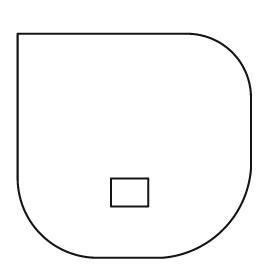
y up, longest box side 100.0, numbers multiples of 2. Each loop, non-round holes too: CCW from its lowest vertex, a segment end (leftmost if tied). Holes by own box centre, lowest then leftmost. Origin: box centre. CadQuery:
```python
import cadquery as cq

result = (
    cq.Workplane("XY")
    .moveTo(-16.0, -48.0)
    .lineTo(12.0, -48.0)
    .threePointArc((38.0, -36.0), (50.0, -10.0))
    .lineTo(50.0, 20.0)
    .threePointArc((42.0, 40.0), (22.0, 48.0))
    .lineTo(-50.0, 48.0)
    .lineTo(-50.0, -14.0)
    .threePointArc((-40.0, -38.0), (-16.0, -48.0))
    .close()
    .moveTo(-10.0, -26.0)
    .lineTo(6.0, -26.0)
    .lineTo(6.0, -14.0)
    .lineTo(-10.0, -14.0)
    .close()
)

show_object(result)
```